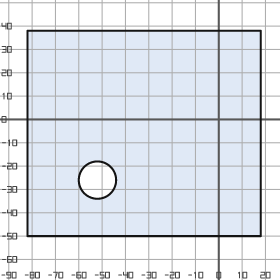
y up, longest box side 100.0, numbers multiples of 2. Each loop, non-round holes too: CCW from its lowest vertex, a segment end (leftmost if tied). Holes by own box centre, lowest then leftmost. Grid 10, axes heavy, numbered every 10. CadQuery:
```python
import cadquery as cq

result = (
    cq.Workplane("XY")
    .moveTo(-82.0, -50.0)
    .lineTo(18.0, -50.0)
    .lineTo(18.0, 38.0)
    .lineTo(-82.0, 38.0)
    .close()
    .moveTo(-52.0, -26.0)
    .circle(8.0)
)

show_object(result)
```